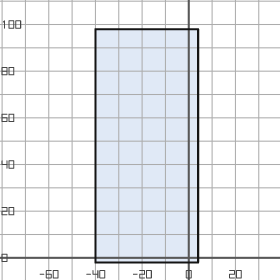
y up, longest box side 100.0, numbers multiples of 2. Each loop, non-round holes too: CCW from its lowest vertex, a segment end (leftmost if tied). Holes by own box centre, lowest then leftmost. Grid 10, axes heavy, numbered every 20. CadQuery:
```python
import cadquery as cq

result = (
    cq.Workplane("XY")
    .moveTo(-40.0, -2.0)
    .lineTo(4.0, -2.0)
    .lineTo(4.0, 98.0)
    .lineTo(-40.0, 98.0)
    .close()
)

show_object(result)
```